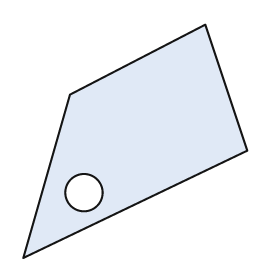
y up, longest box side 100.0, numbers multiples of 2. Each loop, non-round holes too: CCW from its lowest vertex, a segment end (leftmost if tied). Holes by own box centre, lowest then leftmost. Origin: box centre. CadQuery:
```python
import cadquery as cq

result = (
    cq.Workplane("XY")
    .moveTo(-48.0, -50.0)
    .lineTo(48.0, -4.0)
    .lineTo(30.0, 50.0)
    .lineTo(-28.0, 20.0)
    .close()
    .moveTo(-22.0, -22.0)
    .circle(8.0)
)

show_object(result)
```